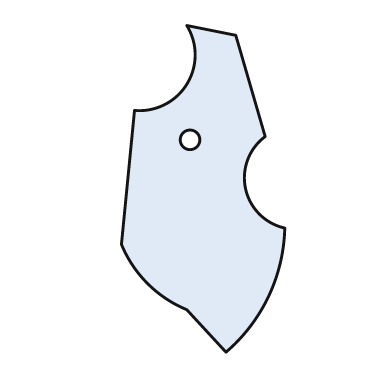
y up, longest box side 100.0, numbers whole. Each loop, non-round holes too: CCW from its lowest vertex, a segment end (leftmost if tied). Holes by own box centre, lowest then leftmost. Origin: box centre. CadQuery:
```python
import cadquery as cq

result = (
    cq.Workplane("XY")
    .moveTo(7.0, -50.0)
    .threePointArc((20.0, -33.0), (25.0, -12.0))
    .threePointArc((13.0, 0.0), (19.0, 16.0))
    .lineTo(10.0, 47.0)
    .lineTo(-5.0, 50.0)
    .threePointArc((-5.0, 32.0), (-21.0, 24.0))
    .lineTo(-25.0, -17.0)
    .threePointArc((-17.0, -29.0), (-5.0, -37.0))
    .close()
    .moveTo(-4.0, 15.0)
    .circle(3.0)
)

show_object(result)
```